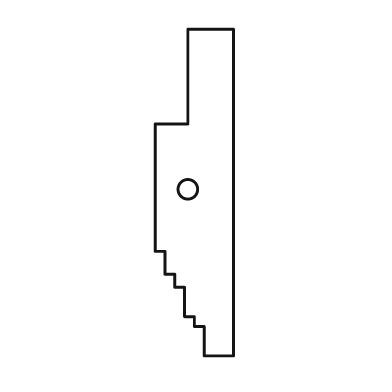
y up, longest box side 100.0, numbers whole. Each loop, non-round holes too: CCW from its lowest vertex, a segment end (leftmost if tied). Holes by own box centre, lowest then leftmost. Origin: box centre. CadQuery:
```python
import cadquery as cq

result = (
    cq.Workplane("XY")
    .moveTo(3.0, -50.0)
    .lineTo(12.0, -50.0)
    .lineTo(12.0, 50.0)
    .lineTo(-2.0, 50.0)
    .lineTo(-2.0, 21.0)
    .lineTo(-12.0, 21.0)
    .lineTo(-12.0, -18.0)
    .lineTo(-9.0, -18.0)
    .lineTo(-9.0, -25.0)
    .lineTo(-6.0, -25.0)
    .lineTo(-6.0, -29.0)
    .lineTo(-3.0, -29.0)
    .lineTo(-3.0, -38.0)
    .lineTo(0.0, -38.0)
    .lineTo(0.0, -41.0)
    .lineTo(3.0, -41.0)
    .close()
    .moveTo(-2.0, 1.0)
    .circle(3.0)
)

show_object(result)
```